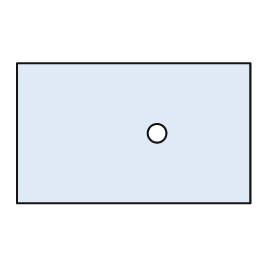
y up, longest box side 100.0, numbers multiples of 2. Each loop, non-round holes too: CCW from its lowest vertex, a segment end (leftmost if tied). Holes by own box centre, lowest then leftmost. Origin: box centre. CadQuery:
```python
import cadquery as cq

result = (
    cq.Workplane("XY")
    .moveTo(-50.0, -30.0)
    .lineTo(50.0, -30.0)
    .lineTo(50.0, 30.0)
    .lineTo(-50.0, 30.0)
    .close()
    .moveTo(10.0, 0.0)
    .circle(4.0)
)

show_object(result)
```